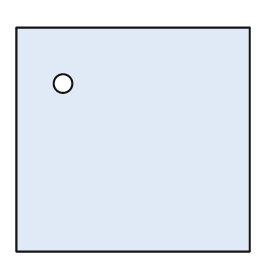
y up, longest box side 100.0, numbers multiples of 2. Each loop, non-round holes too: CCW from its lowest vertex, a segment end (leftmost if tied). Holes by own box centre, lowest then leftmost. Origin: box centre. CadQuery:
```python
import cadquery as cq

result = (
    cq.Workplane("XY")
    .moveTo(-50.0, -48.0)
    .lineTo(50.0, -48.0)
    .lineTo(50.0, 48.0)
    .lineTo(-50.0, 48.0)
    .close()
    .moveTo(-30.0, 24.0)
    .circle(4.0)
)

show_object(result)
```